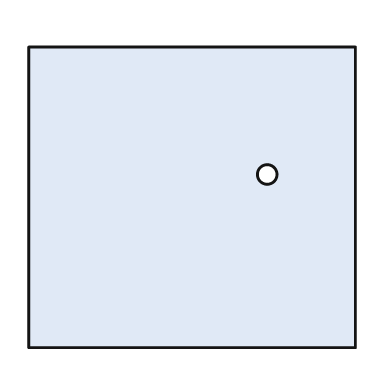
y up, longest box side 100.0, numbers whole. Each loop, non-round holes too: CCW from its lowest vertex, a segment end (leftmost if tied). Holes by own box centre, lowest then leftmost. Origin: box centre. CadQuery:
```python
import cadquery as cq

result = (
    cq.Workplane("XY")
    .moveTo(-50.0, -46.0)
    .lineTo(50.0, -46.0)
    .lineTo(50.0, 46.0)
    .lineTo(-50.0, 46.0)
    .close()
    .moveTo(23.0, 7.0)
    .circle(3.0)
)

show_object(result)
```